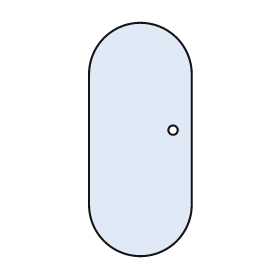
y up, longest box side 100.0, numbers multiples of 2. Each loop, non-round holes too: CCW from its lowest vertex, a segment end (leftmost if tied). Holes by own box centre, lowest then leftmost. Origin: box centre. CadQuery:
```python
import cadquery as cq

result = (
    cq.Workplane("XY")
    .moveTo(-22.0, -28.0)
    .threePointArc((0.0, -50.0), (22.0, -28.0))
    .lineTo(22.0, 28.0)
    .threePointArc((0.0, 50.0), (-22.0, 28.0))
    .close()
    .moveTo(14.0, 4.0)
    .circle(2.0)
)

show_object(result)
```